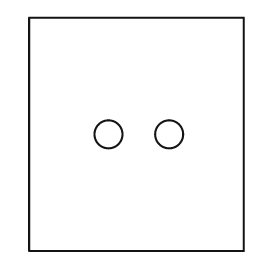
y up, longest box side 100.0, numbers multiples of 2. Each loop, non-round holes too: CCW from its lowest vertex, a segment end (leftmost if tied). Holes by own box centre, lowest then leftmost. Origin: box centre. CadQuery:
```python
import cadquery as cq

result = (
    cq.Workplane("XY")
    .moveTo(-46.0, -50.0)
    .lineTo(46.0, -50.0)
    .lineTo(46.0, 50.0)
    .lineTo(-46.0, 50.0)
    .close()
    .moveTo(-12.0, 0.0)
    .circle(6.0)
    .moveTo(14.0, 0.0)
    .circle(6.0)
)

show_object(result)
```